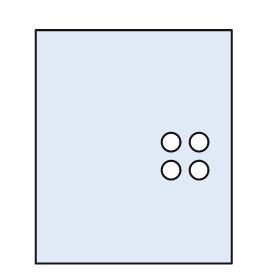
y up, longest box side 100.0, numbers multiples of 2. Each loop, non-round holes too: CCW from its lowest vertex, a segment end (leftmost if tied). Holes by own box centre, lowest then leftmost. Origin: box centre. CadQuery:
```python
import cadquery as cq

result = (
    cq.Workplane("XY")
    .moveTo(-42.0, -50.0)
    .lineTo(42.0, -50.0)
    .lineTo(42.0, 50.0)
    .lineTo(-42.0, 50.0)
    .close()
    .moveTo(16.0, -10.0)
    .circle(4.0)
    .moveTo(28.0, -10.0)
    .circle(4.0)
    .moveTo(16.0, 2.0)
    .circle(4.0)
    .moveTo(28.0, 2.0)
    .circle(4.0)
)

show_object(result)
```